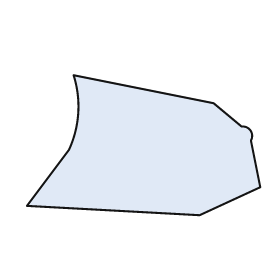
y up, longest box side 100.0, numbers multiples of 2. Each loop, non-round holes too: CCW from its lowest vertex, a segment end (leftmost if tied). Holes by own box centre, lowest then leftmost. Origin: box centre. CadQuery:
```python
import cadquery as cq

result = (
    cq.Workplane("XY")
    .moveTo(24.0, -30.0)
    .lineTo(50.0, -18.0)
    .lineTo(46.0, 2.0)
    .threePointArc((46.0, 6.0), (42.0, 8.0))
    .lineTo(30.0, 18.0)
    .lineTo(-30.0, 30.0)
    .threePointArc((-28.0, 14.0), (-32.0, -2.0))
    .lineTo(-50.0, -26.0)
    .close()
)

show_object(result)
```